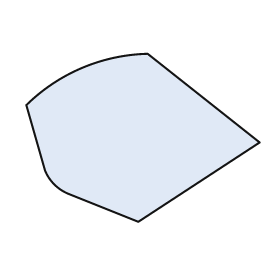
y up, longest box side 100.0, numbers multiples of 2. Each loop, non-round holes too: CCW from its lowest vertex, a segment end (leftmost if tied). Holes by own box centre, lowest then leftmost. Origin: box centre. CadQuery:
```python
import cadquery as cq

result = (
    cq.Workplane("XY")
    .moveTo(-2.0, -36.0)
    .lineTo(50.0, -2.0)
    .lineTo(2.0, 36.0)
    .threePointArc((-26.0, 30.0), (-50.0, 14.0))
    .lineTo(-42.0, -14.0)
    .threePointArc((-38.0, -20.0), (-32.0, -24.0))
    .close()
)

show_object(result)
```